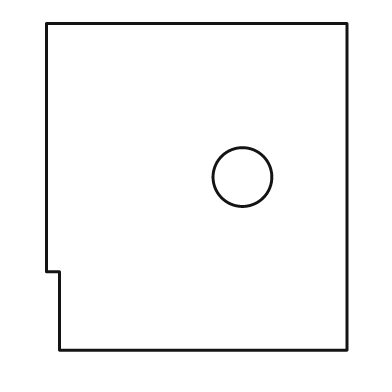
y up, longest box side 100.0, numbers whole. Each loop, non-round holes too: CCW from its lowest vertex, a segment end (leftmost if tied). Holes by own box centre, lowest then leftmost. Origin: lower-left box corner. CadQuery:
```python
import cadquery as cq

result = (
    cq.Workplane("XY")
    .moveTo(4.0, 0.0)
    .lineTo(92.0, 0.0)
    .lineTo(92.0, 100.0)
    .lineTo(0.0, 100.0)
    .lineTo(0.0, 24.0)
    .lineTo(4.0, 24.0)
    .close()
    .moveTo(60.0, 53.0)
    .circle(9.0)
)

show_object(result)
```